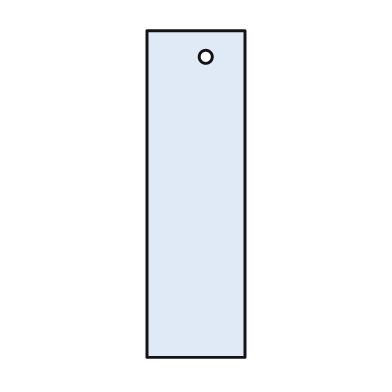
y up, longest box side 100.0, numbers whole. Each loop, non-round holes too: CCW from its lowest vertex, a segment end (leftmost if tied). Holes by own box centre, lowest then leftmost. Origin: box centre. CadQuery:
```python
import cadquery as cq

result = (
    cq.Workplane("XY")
    .moveTo(-15.0, -50.0)
    .lineTo(15.0, -50.0)
    .lineTo(15.0, 50.0)
    .lineTo(-15.0, 50.0)
    .close()
    .moveTo(3.0, 42.0)
    .circle(2.0)
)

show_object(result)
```